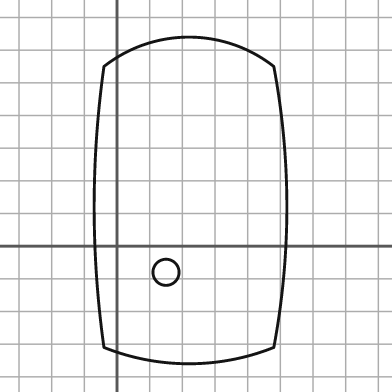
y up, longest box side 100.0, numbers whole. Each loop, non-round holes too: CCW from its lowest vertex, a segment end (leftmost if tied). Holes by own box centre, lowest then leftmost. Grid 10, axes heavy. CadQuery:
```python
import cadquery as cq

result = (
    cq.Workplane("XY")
    .moveTo(-4.0, -31.0)
    .threePointArc((22.0, -36.0), (48.0, -31.0))
    .threePointArc((52.0, 12.0), (48.0, 55.0))
    .threePointArc((22.0, 64.0), (-4.0, 55.0))
    .threePointArc((-7.0, 12.0), (-4.0, -31.0))
    .close()
    .moveTo(15.0, -8.0)
    .circle(4.0)
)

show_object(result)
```